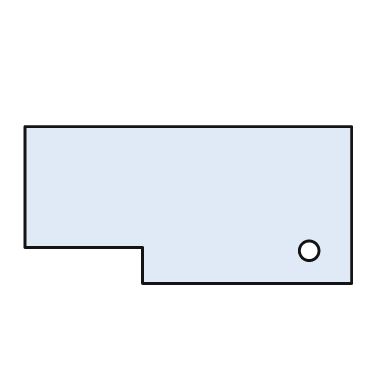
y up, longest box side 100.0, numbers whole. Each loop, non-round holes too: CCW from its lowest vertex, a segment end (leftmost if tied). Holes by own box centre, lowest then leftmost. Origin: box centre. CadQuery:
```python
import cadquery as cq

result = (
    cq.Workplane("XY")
    .moveTo(-14.0, -24.0)
    .lineTo(50.0, -24.0)
    .lineTo(50.0, 24.0)
    .lineTo(-50.0, 24.0)
    .lineTo(-50.0, -13.0)
    .lineTo(-14.0, -13.0)
    .close()
    .moveTo(37.0, -14.0)
    .circle(3.0)
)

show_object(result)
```